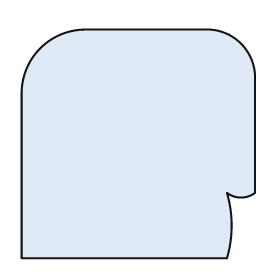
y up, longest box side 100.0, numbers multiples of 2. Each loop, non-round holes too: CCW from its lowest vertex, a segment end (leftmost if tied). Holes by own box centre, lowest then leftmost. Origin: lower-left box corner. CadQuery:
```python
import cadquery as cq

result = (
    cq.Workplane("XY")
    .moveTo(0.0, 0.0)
    .lineTo(88.0, 0.0)
    .threePointArc((90.0, 14.0), (88.0, 28.0))
    .threePointArc((94.0, 26.0), (100.0, 28.0))
    .lineTo(100.0, 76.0)
    .threePointArc((94.0, 92.0), (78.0, 98.0))
    .lineTo(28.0, 98.0)
    .threePointArc((8.0, 90.0), (0.0, 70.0))
    .close()
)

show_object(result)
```